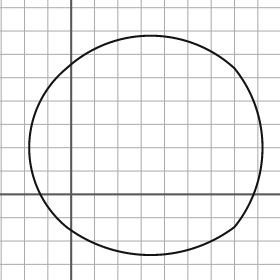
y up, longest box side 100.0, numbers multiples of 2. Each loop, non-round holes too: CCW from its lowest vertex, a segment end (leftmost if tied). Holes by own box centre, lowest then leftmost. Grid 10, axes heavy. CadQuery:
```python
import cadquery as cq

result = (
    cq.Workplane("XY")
    .moveTo(-2.0, -14.0)
    .threePointArc((34.0, -26.0), (70.0, -14.0))
    .threePointArc((82.0, 20.0), (70.0, 54.0))
    .threePointArc((34.0, 68.0), (-2.0, 54.0))
    .threePointArc((-18.0, 20.0), (-2.0, -14.0))
    .close()
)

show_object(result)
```